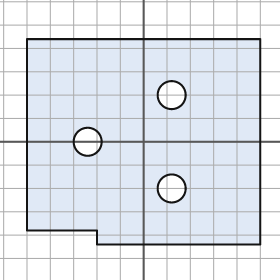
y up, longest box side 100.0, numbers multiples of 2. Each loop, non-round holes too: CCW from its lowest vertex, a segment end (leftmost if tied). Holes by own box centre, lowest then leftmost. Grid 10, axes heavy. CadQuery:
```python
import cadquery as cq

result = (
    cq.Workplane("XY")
    .moveTo(-20.0, -44.0)
    .lineTo(50.0, -44.0)
    .lineTo(50.0, 44.0)
    .lineTo(-50.0, 44.0)
    .lineTo(-50.0, -38.0)
    .lineTo(-20.0, -38.0)
    .close()
    .moveTo(12.0, -20.0)
    .circle(6.0)
    .moveTo(-24.0, 0.0)
    .circle(6.0)
    .moveTo(12.0, 20.0)
    .circle(6.0)
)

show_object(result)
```